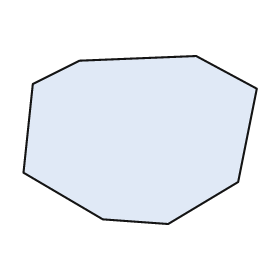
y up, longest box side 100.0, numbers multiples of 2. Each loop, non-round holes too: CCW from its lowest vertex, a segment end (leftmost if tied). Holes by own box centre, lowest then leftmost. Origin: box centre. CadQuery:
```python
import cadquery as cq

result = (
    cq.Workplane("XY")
    .moveTo(12.0, -36.0)
    .lineTo(42.0, -18.0)
    .lineTo(50.0, 22.0)
    .lineTo(24.0, 36.0)
    .lineTo(-26.0, 34.0)
    .lineTo(-46.0, 24.0)
    .lineTo(-50.0, -14.0)
    .lineTo(-16.0, -34.0)
    .close()
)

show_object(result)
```